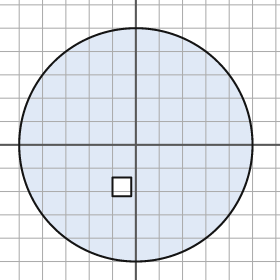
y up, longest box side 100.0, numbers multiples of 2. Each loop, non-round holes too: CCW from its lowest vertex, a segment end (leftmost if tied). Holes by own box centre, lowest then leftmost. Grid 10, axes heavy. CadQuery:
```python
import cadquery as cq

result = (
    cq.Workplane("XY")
    .moveTo(0.0, 0.0)
    .circle(50.0)
    .moveTo(-10.0, -22.0)
    .lineTo(-2.0, -22.0)
    .lineTo(-2.0, -14.0)
    .lineTo(-10.0, -14.0)
    .close()
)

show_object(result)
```